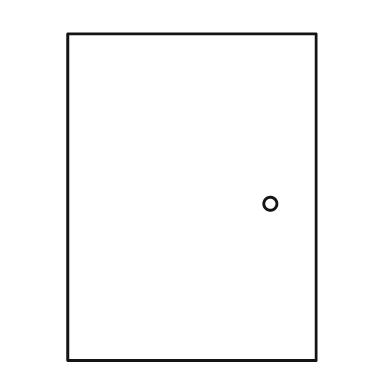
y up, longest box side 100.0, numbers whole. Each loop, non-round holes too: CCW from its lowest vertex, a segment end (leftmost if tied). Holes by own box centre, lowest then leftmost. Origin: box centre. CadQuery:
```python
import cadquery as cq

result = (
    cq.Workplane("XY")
    .moveTo(-38.0, -50.0)
    .lineTo(38.0, -50.0)
    .lineTo(38.0, 50.0)
    .lineTo(-38.0, 50.0)
    .close()
    .moveTo(24.0, -2.0)
    .circle(2.0)
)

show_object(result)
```